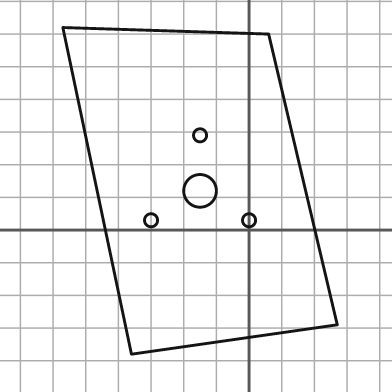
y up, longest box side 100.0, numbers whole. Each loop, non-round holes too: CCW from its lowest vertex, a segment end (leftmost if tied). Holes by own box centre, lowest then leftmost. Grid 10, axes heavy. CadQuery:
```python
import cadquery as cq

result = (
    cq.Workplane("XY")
    .moveTo(-36.0, -38.0)
    .lineTo(27.0, -29.0)
    .lineTo(6.0, 60.0)
    .lineTo(-57.0, 62.0)
    .close()
    .moveTo(-30.0, 3.0)
    .circle(2.0)
    .moveTo(0.0, 3.0)
    .circle(2.0)
    .moveTo(-15.0, 12.0)
    .circle(5.0)
    .moveTo(-15.0, 29.0)
    .circle(2.0)
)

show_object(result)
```